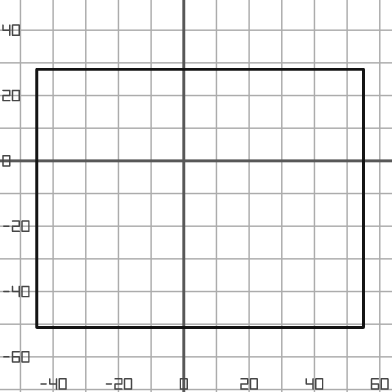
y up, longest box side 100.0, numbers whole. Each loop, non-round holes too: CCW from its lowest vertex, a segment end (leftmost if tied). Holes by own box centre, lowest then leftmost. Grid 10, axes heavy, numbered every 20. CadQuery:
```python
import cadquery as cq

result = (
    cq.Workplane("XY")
    .moveTo(-45.0, -51.0)
    .lineTo(55.0, -51.0)
    .lineTo(55.0, 28.0)
    .lineTo(-45.0, 28.0)
    .close()
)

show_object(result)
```